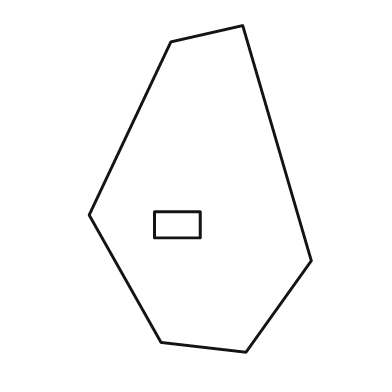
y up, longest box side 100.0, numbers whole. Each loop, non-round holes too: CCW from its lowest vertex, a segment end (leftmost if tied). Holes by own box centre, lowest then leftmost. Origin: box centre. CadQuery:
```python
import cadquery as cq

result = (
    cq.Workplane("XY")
    .moveTo(14.0, -50.0)
    .lineTo(34.0, -22.0)
    .lineTo(13.0, 50.0)
    .lineTo(-9.0, 45.0)
    .lineTo(-34.0, -8.0)
    .lineTo(-12.0, -47.0)
    .close()
    .moveTo(-14.0, -15.0)
    .lineTo(0.0, -15.0)
    .lineTo(0.0, -7.0)
    .lineTo(-14.0, -7.0)
    .close()
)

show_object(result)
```